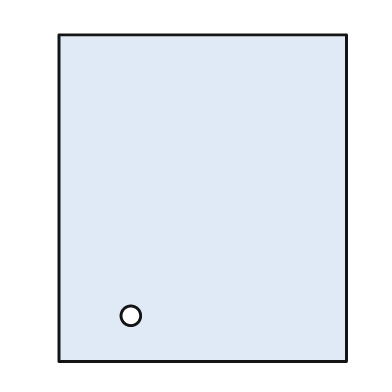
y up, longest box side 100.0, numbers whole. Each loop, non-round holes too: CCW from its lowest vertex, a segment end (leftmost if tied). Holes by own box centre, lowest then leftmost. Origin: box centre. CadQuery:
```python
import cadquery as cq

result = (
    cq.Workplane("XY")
    .moveTo(-44.0, -50.0)
    .lineTo(44.0, -50.0)
    .lineTo(44.0, 50.0)
    .lineTo(-44.0, 50.0)
    .close()
    .moveTo(-22.0, -36.0)
    .circle(3.0)
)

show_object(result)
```